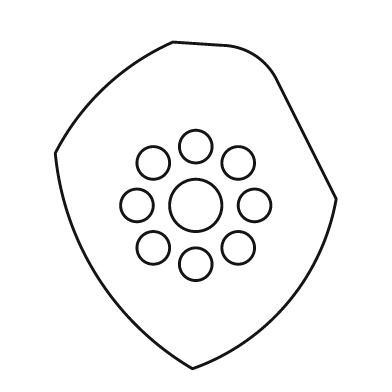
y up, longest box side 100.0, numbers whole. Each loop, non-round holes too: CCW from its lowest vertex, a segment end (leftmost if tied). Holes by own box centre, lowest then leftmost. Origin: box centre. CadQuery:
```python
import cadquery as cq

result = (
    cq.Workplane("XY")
    .moveTo(-1.0, -50.0)
    .threePointArc((28.0, -30.0), (43.0, 2.0))
    .lineTo(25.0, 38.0)
    .threePointArc((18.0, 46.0), (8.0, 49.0))
    .lineTo(-7.0, 50.0)
    .threePointArc((-28.0, 36.0), (-43.0, 16.0))
    .threePointArc((-30.0, -22.0), (-1.0, -50.0))
    .close()
    .moveTo(0.0, -18.0)
    .circle(5.0)
    .moveTo(-13.0, -13.0)
    .circle(5.0)
    .moveTo(13.0, -13.0)
    .circle(5.0)
    .moveTo(-18.0, 0.0)
    .circle(5.0)
    .moveTo(0.0, 0.0)
    .circle(8.0)
    .moveTo(18.0, 0.0)
    .circle(5.0)
    .moveTo(-13.0, 13.0)
    .circle(5.0)
    .moveTo(13.0, 13.0)
    .circle(5.0)
    .moveTo(0.0, 18.0)
    .circle(5.0)
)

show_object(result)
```